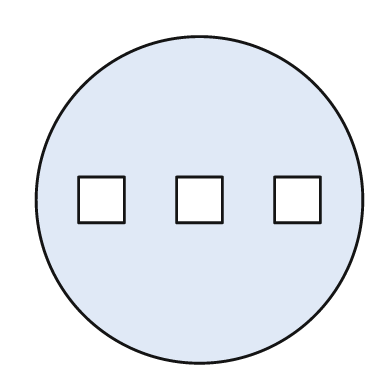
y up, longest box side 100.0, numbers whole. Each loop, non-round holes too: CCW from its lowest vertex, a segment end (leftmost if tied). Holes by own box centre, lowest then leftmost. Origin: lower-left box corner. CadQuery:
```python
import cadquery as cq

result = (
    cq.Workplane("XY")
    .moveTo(50.0, 50.0)
    .circle(50.0)
    .moveTo(13.0, 43.0)
    .lineTo(27.0, 43.0)
    .lineTo(27.0, 57.0)
    .lineTo(13.0, 57.0)
    .close()
    .moveTo(43.0, 43.0)
    .lineTo(57.0, 43.0)
    .lineTo(57.0, 57.0)
    .lineTo(43.0, 57.0)
    .close()
    .moveTo(73.0, 43.0)
    .lineTo(87.0, 43.0)
    .lineTo(87.0, 57.0)
    .lineTo(73.0, 57.0)
    .close()
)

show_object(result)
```